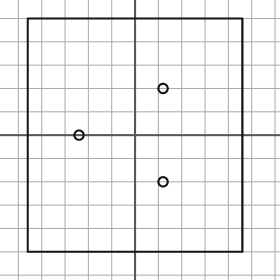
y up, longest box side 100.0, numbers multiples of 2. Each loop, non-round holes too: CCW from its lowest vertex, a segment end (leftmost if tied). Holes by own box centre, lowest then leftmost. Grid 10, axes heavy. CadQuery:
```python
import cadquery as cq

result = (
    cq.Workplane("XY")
    .moveTo(-46.0, -50.0)
    .lineTo(46.0, -50.0)
    .lineTo(46.0, 50.0)
    .lineTo(-46.0, 50.0)
    .close()
    .moveTo(12.0, -20.0)
    .circle(2.0)
    .moveTo(-24.0, 0.0)
    .circle(2.0)
    .moveTo(12.0, 20.0)
    .circle(2.0)
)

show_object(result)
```